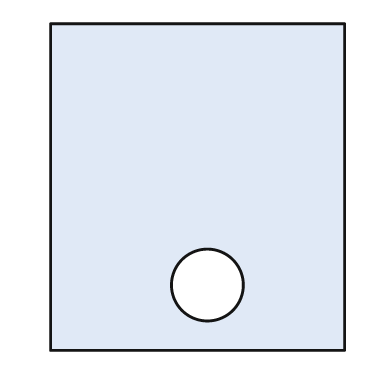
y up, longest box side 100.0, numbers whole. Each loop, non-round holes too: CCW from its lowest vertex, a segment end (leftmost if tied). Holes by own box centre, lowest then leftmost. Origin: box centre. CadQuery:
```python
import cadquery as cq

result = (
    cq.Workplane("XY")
    .moveTo(-45.0, -50.0)
    .lineTo(45.0, -50.0)
    .lineTo(45.0, 50.0)
    .lineTo(-45.0, 50.0)
    .close()
    .moveTo(3.0, -30.0)
    .circle(11.0)
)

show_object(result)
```